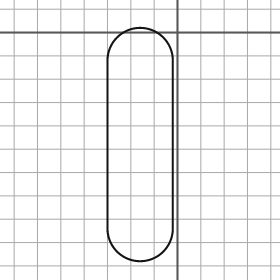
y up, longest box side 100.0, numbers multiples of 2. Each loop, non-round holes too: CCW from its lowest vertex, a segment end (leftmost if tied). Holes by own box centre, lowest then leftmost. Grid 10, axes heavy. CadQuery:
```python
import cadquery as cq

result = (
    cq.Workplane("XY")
    .moveTo(-30.0, -84.0)
    .threePointArc((-16.0, -98.0), (-2.0, -84.0))
    .lineTo(-2.0, -12.0)
    .threePointArc((-16.0, 2.0), (-30.0, -12.0))
    .close()
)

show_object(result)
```